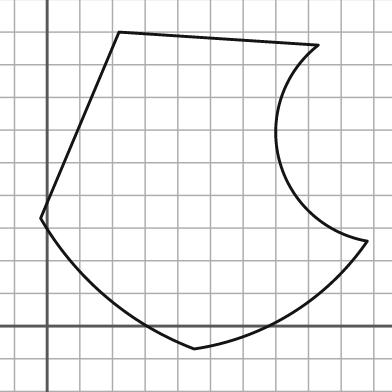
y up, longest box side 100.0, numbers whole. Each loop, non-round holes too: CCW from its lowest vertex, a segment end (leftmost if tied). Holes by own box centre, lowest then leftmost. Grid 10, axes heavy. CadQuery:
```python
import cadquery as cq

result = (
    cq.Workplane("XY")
    .moveTo(45.0, -7.0)
    .threePointArc((75.0, 4.0), (98.0, 26.0))
    .threePointArc((71.0, 51.0), (83.0, 86.0))
    .lineTo(22.0, 90.0)
    .lineTo(-2.0, 33.0)
    .threePointArc((18.0, 9.0), (45.0, -7.0))
    .close()
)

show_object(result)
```